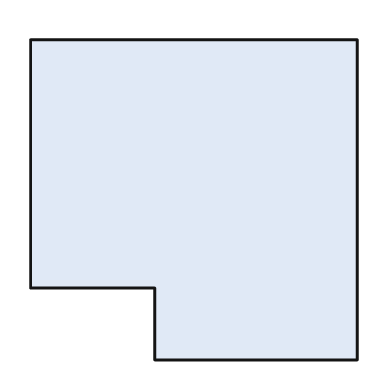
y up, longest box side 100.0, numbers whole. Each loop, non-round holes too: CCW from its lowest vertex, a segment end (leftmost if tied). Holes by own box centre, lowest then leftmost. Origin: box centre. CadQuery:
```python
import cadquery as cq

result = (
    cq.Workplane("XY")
    .moveTo(-12.0, -49.0)
    .lineTo(50.0, -49.0)
    .lineTo(50.0, 49.0)
    .lineTo(-50.0, 49.0)
    .lineTo(-50.0, -27.0)
    .lineTo(-12.0, -27.0)
    .close()
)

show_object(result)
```